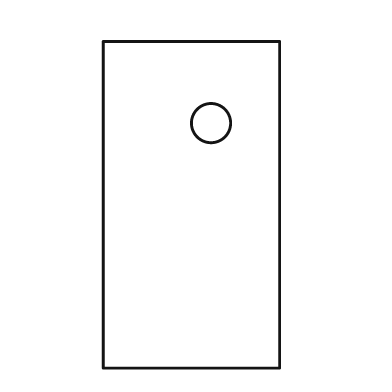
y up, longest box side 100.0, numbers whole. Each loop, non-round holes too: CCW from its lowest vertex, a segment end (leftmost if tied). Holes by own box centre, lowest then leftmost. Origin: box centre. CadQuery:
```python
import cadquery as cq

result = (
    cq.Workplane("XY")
    .moveTo(-27.0, -50.0)
    .lineTo(27.0, -50.0)
    .lineTo(27.0, 50.0)
    .lineTo(-27.0, 50.0)
    .close()
    .moveTo(6.0, 25.0)
    .circle(6.0)
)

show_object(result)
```